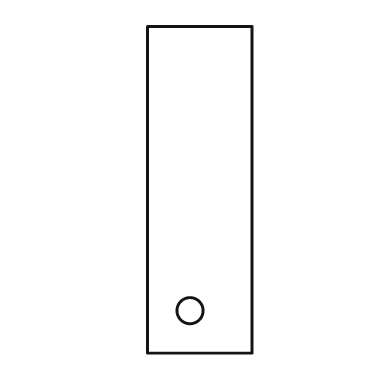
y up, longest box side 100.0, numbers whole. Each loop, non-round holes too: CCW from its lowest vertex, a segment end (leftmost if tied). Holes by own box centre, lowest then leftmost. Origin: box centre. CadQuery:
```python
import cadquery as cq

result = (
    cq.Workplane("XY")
    .moveTo(-16.0, -50.0)
    .lineTo(16.0, -50.0)
    .lineTo(16.0, 50.0)
    .lineTo(-16.0, 50.0)
    .close()
    .moveTo(-3.0, -37.0)
    .circle(4.0)
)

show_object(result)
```